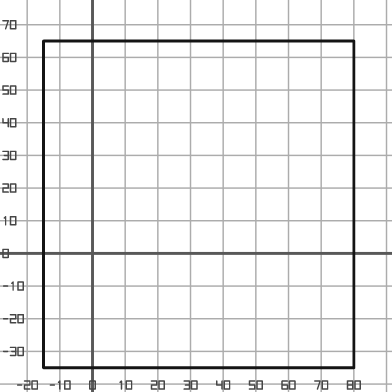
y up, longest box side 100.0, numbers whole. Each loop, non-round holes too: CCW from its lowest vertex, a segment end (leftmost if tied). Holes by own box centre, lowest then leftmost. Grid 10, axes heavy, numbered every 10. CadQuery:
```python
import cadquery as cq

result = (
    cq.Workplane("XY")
    .moveTo(-15.0, -35.0)
    .lineTo(80.0, -35.0)
    .lineTo(80.0, 65.0)
    .lineTo(-15.0, 65.0)
    .close()
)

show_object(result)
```